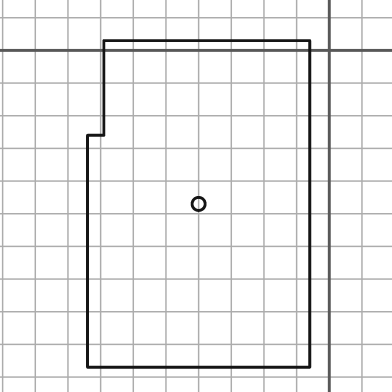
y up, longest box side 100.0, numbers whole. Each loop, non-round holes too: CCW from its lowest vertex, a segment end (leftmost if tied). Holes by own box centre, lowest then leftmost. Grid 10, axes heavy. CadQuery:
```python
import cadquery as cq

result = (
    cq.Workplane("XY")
    .moveTo(-74.0, -97.0)
    .lineTo(-6.0, -97.0)
    .lineTo(-6.0, 3.0)
    .lineTo(-69.0, 3.0)
    .lineTo(-69.0, -26.0)
    .lineTo(-74.0, -26.0)
    .close()
    .moveTo(-40.0, -47.0)
    .circle(2.0)
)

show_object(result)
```